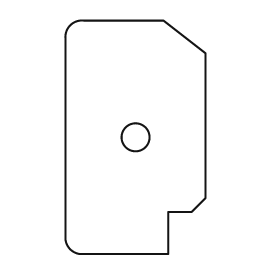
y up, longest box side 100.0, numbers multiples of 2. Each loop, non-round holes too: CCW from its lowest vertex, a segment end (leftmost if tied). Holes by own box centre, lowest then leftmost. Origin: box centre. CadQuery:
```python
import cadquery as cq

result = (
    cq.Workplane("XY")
    .moveTo(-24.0, -50.0)
    .lineTo(14.0, -50.0)
    .lineTo(14.0, -32.0)
    .lineTo(24.0, -32.0)
    .lineTo(30.0, -26.0)
    .lineTo(30.0, 36.0)
    .lineTo(12.0, 50.0)
    .lineTo(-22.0, 50.0)
    .threePointArc((-28.0, 48.0), (-30.0, 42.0))
    .lineTo(-30.0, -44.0)
    .threePointArc((-28.0, -48.0), (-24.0, -50.0))
    .close()
    .moveTo(0.0, 0.0)
    .circle(6.0)
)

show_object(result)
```